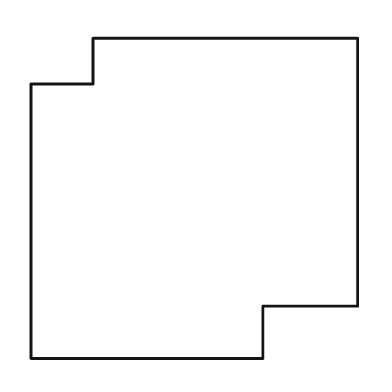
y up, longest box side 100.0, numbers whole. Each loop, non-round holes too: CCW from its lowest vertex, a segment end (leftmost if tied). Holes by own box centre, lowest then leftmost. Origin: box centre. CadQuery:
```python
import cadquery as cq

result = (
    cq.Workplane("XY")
    .moveTo(-50.0, -49.0)
    .lineTo(21.0, -49.0)
    .lineTo(21.0, -33.0)
    .lineTo(50.0, -33.0)
    .lineTo(50.0, 49.0)
    .lineTo(-31.0, 49.0)
    .lineTo(-31.0, 35.0)
    .lineTo(-50.0, 35.0)
    .close()
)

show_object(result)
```